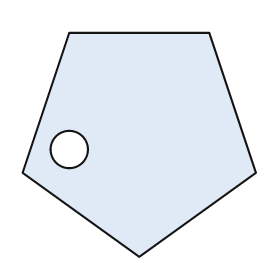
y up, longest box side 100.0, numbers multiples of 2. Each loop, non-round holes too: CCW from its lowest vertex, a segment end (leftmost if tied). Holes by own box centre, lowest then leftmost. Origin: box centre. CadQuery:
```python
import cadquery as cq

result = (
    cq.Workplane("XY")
    .moveTo(0.0, -48.0)
    .lineTo(50.0, -12.0)
    .lineTo(30.0, 48.0)
    .lineTo(-30.0, 48.0)
    .lineTo(-50.0, -12.0)
    .close()
    .moveTo(-30.0, -2.0)
    .circle(8.0)
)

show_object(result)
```